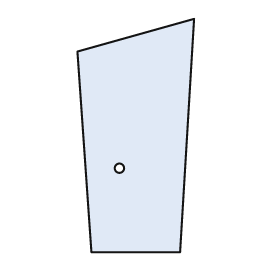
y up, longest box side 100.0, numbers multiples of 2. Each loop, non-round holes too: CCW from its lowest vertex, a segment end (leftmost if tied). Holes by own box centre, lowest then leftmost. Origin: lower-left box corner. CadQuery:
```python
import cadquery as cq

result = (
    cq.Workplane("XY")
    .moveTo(6.0, 0.0)
    .lineTo(44.0, 0.0)
    .lineTo(50.0, 100.0)
    .lineTo(0.0, 86.0)
    .close()
    .moveTo(18.0, 36.0)
    .circle(2.0)
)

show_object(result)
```